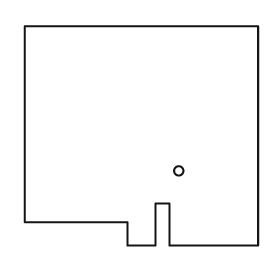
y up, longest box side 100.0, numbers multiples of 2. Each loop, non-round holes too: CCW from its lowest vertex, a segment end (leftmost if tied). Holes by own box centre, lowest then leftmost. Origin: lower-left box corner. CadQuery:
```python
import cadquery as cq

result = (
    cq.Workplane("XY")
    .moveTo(44.0, 0.0)
    .lineTo(56.0, 0.0)
    .lineTo(56.0, 18.0)
    .lineTo(62.0, 18.0)
    .lineTo(62.0, 0.0)
    .lineTo(100.0, 0.0)
    .lineTo(100.0, 94.0)
    .lineTo(0.0, 94.0)
    .lineTo(0.0, 10.0)
    .lineTo(44.0, 10.0)
    .close()
    .moveTo(66.0, 32.0)
    .circle(2.0)
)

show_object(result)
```